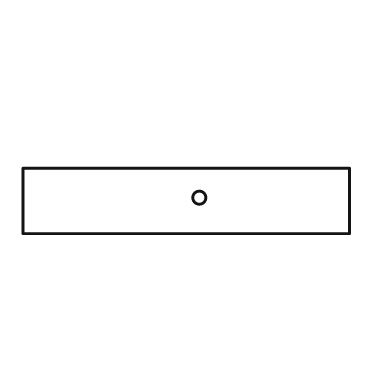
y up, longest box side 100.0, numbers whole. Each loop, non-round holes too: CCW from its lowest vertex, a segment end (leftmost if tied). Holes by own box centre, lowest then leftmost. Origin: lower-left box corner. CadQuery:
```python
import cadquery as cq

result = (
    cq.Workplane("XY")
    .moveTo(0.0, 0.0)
    .lineTo(100.0, 0.0)
    .lineTo(100.0, 20.0)
    .lineTo(0.0, 20.0)
    .close()
    .moveTo(54.0, 11.0)
    .circle(2.0)
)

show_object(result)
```